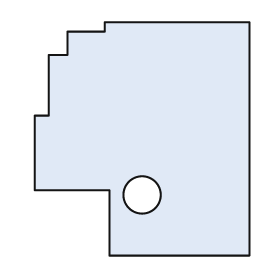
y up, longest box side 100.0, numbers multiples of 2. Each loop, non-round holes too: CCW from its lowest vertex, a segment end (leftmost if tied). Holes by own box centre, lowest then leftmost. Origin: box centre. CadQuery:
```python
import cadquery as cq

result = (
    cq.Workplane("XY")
    .moveTo(-14.0, -50.0)
    .lineTo(46.0, -50.0)
    .lineTo(46.0, 50.0)
    .lineTo(-16.0, 50.0)
    .lineTo(-16.0, 46.0)
    .lineTo(-32.0, 46.0)
    .lineTo(-32.0, 36.0)
    .lineTo(-40.0, 36.0)
    .lineTo(-40.0, 10.0)
    .lineTo(-46.0, 10.0)
    .lineTo(-46.0, -22.0)
    .lineTo(-14.0, -22.0)
    .close()
    .moveTo(0.0, -24.0)
    .circle(8.0)
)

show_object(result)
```